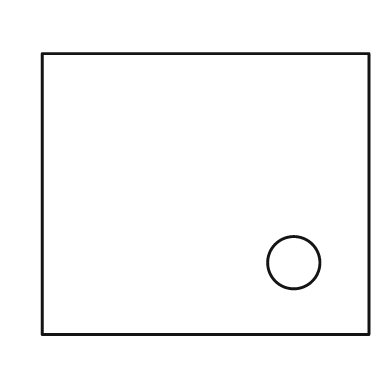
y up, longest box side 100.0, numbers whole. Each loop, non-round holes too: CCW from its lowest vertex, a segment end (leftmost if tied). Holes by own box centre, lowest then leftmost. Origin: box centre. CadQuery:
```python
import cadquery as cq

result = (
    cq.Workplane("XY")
    .moveTo(-50.0, -43.0)
    .lineTo(50.0, -43.0)
    .lineTo(50.0, 43.0)
    .lineTo(-50.0, 43.0)
    .close()
    .moveTo(27.0, -21.0)
    .circle(8.0)
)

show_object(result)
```